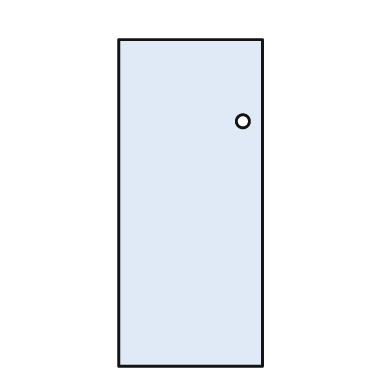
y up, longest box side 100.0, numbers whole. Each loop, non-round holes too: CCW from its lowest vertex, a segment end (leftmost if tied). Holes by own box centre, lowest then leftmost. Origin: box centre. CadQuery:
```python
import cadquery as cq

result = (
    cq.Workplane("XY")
    .moveTo(-22.0, -50.0)
    .lineTo(22.0, -50.0)
    .lineTo(22.0, 50.0)
    .lineTo(-22.0, 50.0)
    .close()
    .moveTo(16.0, 25.0)
    .circle(2.0)
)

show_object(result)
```